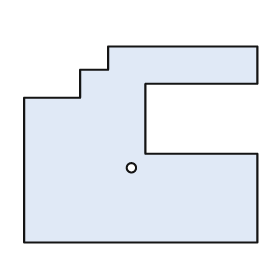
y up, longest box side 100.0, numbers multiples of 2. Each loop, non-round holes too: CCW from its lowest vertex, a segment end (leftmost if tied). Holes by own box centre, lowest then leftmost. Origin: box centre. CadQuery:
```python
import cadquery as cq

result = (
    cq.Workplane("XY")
    .moveTo(-50.0, -42.0)
    .lineTo(50.0, -42.0)
    .lineTo(50.0, -4.0)
    .lineTo(2.0, -4.0)
    .lineTo(2.0, 26.0)
    .lineTo(50.0, 26.0)
    .lineTo(50.0, 42.0)
    .lineTo(-14.0, 42.0)
    .lineTo(-14.0, 32.0)
    .lineTo(-26.0, 32.0)
    .lineTo(-26.0, 20.0)
    .lineTo(-50.0, 20.0)
    .close()
    .moveTo(-4.0, -10.0)
    .circle(2.0)
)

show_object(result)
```